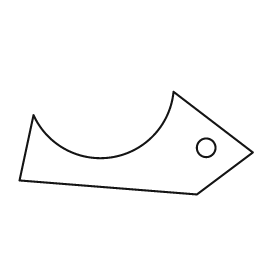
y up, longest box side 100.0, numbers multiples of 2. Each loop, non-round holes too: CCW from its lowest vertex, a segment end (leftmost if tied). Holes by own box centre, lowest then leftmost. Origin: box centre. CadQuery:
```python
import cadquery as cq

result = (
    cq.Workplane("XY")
    .moveTo(26.0, -22.0)
    .lineTo(50.0, -4.0)
    .lineTo(16.0, 22.0)
    .threePointArc((-10.0, -6.0), (-44.0, 12.0))
    .lineTo(-50.0, -16.0)
    .close()
    .moveTo(30.0, -2.0)
    .circle(4.0)
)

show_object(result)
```